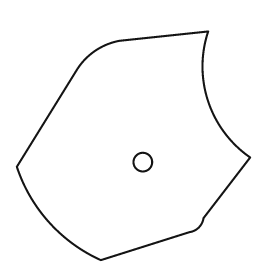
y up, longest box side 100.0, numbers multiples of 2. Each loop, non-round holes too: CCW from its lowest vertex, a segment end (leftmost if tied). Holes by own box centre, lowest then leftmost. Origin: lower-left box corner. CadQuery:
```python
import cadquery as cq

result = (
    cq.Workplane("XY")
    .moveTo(36.0, 0.0)
    .lineTo(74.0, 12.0)
    .threePointArc((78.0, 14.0), (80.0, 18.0))
    .lineTo(100.0, 44.0)
    .threePointArc((82.0, 68.0), (82.0, 98.0))
    .lineTo(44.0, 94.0)
    .threePointArc((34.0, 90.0), (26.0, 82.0))
    .lineTo(0.0, 40.0)
    .threePointArc((14.0, 16.0), (36.0, 0.0))
    .close()
    .moveTo(54.0, 42.0)
    .circle(4.0)
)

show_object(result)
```